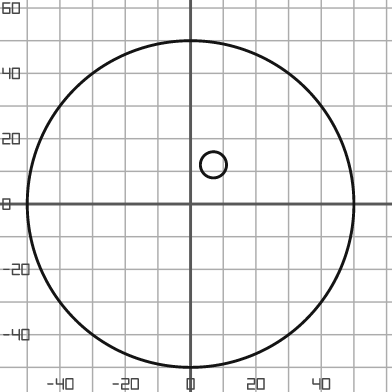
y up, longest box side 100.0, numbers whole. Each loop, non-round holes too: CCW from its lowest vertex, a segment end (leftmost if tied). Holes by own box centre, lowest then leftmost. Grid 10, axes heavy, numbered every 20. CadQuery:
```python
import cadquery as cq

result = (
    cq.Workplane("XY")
    .moveTo(0.0, 0.0)
    .circle(50.0)
    .moveTo(7.0, 12.0)
    .circle(4.0)
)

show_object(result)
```